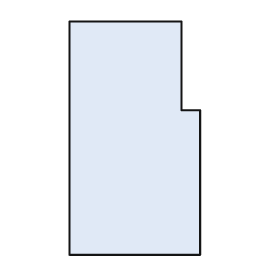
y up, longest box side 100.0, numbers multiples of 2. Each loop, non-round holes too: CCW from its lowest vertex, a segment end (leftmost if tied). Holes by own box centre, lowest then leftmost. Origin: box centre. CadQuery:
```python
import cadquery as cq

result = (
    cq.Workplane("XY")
    .moveTo(-28.0, -50.0)
    .lineTo(28.0, -50.0)
    .lineTo(28.0, 12.0)
    .lineTo(20.0, 12.0)
    .lineTo(20.0, 50.0)
    .lineTo(-28.0, 50.0)
    .close()
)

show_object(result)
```